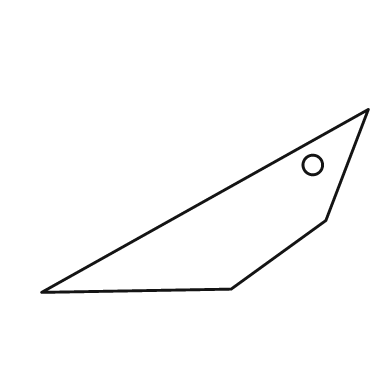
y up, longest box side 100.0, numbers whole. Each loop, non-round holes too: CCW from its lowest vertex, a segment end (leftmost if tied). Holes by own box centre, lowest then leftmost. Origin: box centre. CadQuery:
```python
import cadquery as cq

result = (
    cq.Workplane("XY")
    .moveTo(-50.0, -28.0)
    .lineTo(8.0, -27.0)
    .lineTo(37.0, -6.0)
    .lineTo(50.0, 28.0)
    .close()
    .moveTo(33.0, 11.0)
    .circle(3.0)
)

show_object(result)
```